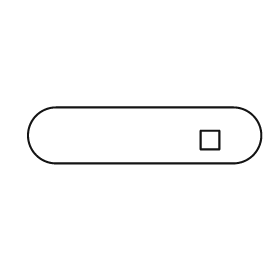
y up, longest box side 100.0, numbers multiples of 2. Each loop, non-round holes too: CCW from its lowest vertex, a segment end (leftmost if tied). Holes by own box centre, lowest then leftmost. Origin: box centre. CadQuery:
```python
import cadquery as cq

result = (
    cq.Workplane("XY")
    .moveTo(-38.0, -12.0)
    .lineTo(38.0, -12.0)
    .threePointArc((50.0, 0.0), (38.0, 12.0))
    .lineTo(-38.0, 12.0)
    .threePointArc((-50.0, 0.0), (-38.0, -12.0))
    .close()
    .moveTo(24.0, -6.0)
    .lineTo(32.0, -6.0)
    .lineTo(32.0, 2.0)
    .lineTo(24.0, 2.0)
    .close()
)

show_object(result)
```